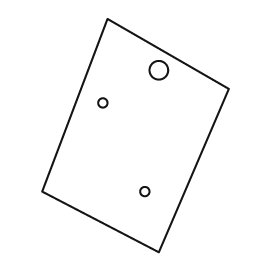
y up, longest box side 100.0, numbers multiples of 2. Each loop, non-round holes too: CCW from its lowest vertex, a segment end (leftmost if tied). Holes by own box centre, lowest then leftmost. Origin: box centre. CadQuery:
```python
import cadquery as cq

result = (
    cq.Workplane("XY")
    .moveTo(10.0, -50.0)
    .lineTo(40.0, 20.0)
    .lineTo(-12.0, 50.0)
    .lineTo(-40.0, -24.0)
    .close()
    .moveTo(4.0, -24.0)
    .circle(2.0)
    .moveTo(-14.0, 14.0)
    .circle(2.0)
    .moveTo(10.0, 28.0)
    .circle(4.0)
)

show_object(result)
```